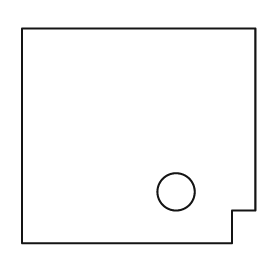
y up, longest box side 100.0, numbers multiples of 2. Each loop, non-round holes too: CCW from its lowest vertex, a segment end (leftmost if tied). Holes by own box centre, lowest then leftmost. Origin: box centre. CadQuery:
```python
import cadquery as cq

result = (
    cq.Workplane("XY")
    .moveTo(-50.0, -46.0)
    .lineTo(40.0, -46.0)
    .lineTo(40.0, -32.0)
    .lineTo(50.0, -32.0)
    .lineTo(50.0, 46.0)
    .lineTo(-50.0, 46.0)
    .close()
    .moveTo(16.0, -24.0)
    .circle(8.0)
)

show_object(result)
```